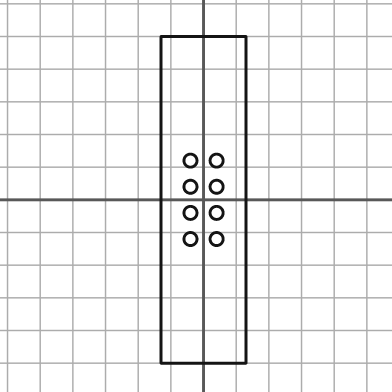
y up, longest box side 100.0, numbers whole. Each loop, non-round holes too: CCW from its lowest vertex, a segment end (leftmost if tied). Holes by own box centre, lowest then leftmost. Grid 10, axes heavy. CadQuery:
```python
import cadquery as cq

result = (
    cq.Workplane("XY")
    .moveTo(-13.0, -50.0)
    .lineTo(13.0, -50.0)
    .lineTo(13.0, 50.0)
    .lineTo(-13.0, 50.0)
    .close()
    .moveTo(-4.0, -12.0)
    .circle(2.0)
    .moveTo(4.0, -12.0)
    .circle(2.0)
    .moveTo(-4.0, -4.0)
    .circle(2.0)
    .moveTo(4.0, -4.0)
    .circle(2.0)
    .moveTo(-4.0, 4.0)
    .circle(2.0)
    .moveTo(4.0, 4.0)
    .circle(2.0)
    .moveTo(-4.0, 12.0)
    .circle(2.0)
    .moveTo(4.0, 12.0)
    .circle(2.0)
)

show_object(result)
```